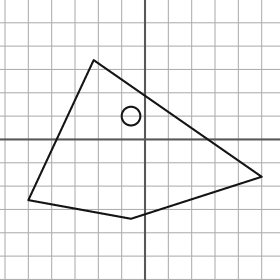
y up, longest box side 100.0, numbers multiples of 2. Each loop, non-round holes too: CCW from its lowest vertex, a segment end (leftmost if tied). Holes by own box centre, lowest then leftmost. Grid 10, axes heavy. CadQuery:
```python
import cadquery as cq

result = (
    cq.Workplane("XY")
    .moveTo(-6.0, -34.0)
    .lineTo(50.0, -16.0)
    .lineTo(-22.0, 34.0)
    .lineTo(-50.0, -26.0)
    .close()
    .moveTo(-6.0, 10.0)
    .circle(4.0)
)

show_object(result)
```